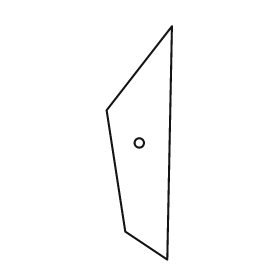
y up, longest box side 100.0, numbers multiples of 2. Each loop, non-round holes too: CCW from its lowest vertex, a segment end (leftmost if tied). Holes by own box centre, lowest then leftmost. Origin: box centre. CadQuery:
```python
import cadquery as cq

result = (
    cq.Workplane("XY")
    .moveTo(12.0, -50.0)
    .lineTo(14.0, 50.0)
    .lineTo(-14.0, 14.0)
    .lineTo(-6.0, -38.0)
    .close()
    .moveTo(0.0, 0.0)
    .circle(2.0)
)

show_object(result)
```